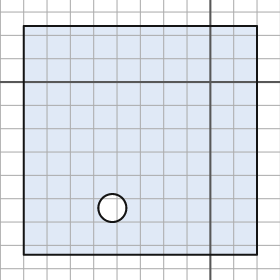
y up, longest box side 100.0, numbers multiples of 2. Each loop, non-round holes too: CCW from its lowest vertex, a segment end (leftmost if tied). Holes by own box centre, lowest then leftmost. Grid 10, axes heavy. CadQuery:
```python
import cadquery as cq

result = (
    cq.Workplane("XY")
    .moveTo(-80.0, -74.0)
    .lineTo(20.0, -74.0)
    .lineTo(20.0, 24.0)
    .lineTo(-80.0, 24.0)
    .close()
    .moveTo(-42.0, -54.0)
    .circle(6.0)
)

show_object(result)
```